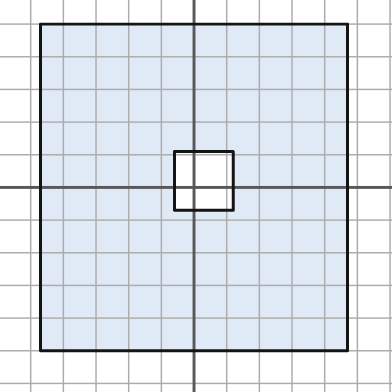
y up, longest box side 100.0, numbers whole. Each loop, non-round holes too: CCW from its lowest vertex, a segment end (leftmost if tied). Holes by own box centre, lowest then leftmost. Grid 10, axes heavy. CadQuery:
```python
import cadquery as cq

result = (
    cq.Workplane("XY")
    .moveTo(-47.0, -50.0)
    .lineTo(47.0, -50.0)
    .lineTo(47.0, 50.0)
    .lineTo(-47.0, 50.0)
    .close()
    .moveTo(-6.0, -7.0)
    .lineTo(12.0, -7.0)
    .lineTo(12.0, 11.0)
    .lineTo(-6.0, 11.0)
    .close()
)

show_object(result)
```